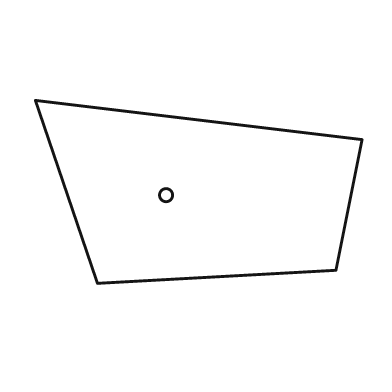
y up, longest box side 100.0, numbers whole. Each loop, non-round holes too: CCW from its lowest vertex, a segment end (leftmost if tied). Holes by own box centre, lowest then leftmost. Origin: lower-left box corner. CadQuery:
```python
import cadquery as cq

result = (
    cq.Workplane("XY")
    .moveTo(19.0, 0.0)
    .lineTo(92.0, 4.0)
    .lineTo(100.0, 44.0)
    .lineTo(0.0, 56.0)
    .close()
    .moveTo(40.0, 27.0)
    .circle(2.0)
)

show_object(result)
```